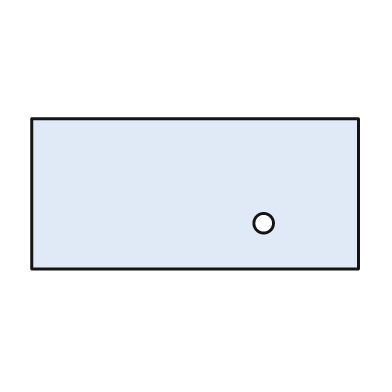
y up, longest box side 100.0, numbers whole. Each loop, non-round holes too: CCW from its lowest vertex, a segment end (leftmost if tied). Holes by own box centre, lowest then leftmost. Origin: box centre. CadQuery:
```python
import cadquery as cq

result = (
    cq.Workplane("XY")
    .moveTo(-50.0, -23.0)
    .lineTo(50.0, -23.0)
    .lineTo(50.0, 23.0)
    .lineTo(-50.0, 23.0)
    .close()
    .moveTo(21.0, -9.0)
    .circle(3.0)
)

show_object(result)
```